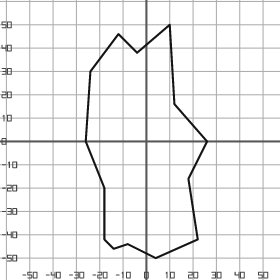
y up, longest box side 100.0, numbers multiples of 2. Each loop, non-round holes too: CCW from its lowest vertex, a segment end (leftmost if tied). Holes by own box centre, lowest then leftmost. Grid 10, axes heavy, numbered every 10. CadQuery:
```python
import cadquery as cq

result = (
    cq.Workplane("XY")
    .moveTo(4.0, -50.0)
    .lineTo(22.0, -42.0)
    .lineTo(18.0, -16.0)
    .lineTo(26.0, 0.0)
    .lineTo(12.0, 16.0)
    .lineTo(10.0, 50.0)
    .lineTo(-4.0, 38.0)
    .lineTo(-12.0, 46.0)
    .lineTo(-24.0, 30.0)
    .lineTo(-26.0, 0.0)
    .lineTo(-18.0, -20.0)
    .lineTo(-18.0, -42.0)
    .lineTo(-14.0, -46.0)
    .lineTo(-8.0, -44.0)
    .close()
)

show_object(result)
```